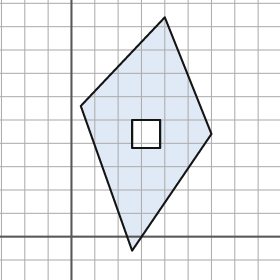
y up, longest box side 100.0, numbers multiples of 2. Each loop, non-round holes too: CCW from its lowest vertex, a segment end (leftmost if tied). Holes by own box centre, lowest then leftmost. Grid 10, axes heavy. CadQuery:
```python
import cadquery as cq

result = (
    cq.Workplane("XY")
    .moveTo(26.0, -6.0)
    .lineTo(60.0, 44.0)
    .lineTo(40.0, 94.0)
    .lineTo(4.0, 56.0)
    .close()
    .moveTo(26.0, 38.0)
    .lineTo(38.0, 38.0)
    .lineTo(38.0, 50.0)
    .lineTo(26.0, 50.0)
    .close()
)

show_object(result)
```